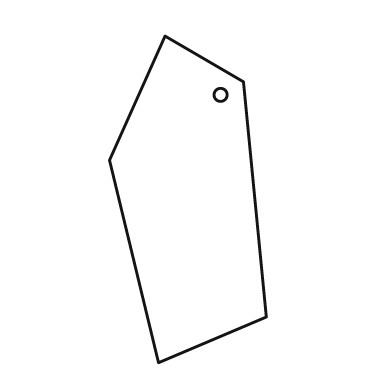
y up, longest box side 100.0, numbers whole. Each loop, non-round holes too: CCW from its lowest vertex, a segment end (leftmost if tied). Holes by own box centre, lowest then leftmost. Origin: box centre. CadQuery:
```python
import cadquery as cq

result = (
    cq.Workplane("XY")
    .moveTo(-9.0, -50.0)
    .lineTo(24.0, -36.0)
    .lineTo(17.0, 36.0)
    .lineTo(-7.0, 50.0)
    .lineTo(-24.0, 12.0)
    .close()
    .moveTo(10.0, 32.0)
    .circle(2.0)
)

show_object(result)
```